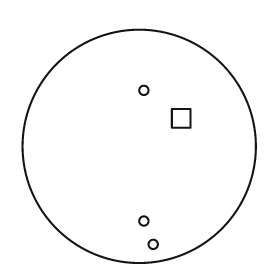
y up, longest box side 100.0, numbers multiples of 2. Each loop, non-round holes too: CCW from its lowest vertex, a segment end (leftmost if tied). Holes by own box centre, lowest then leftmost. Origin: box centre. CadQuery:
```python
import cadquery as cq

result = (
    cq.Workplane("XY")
    .moveTo(0.0, 0.0)
    .circle(50.0)
    .moveTo(6.0, -42.0)
    .circle(2.0)
    .moveTo(2.0, -32.0)
    .circle(2.0)
    .moveTo(14.0, 8.0)
    .lineTo(22.0, 8.0)
    .lineTo(22.0, 16.0)
    .lineTo(14.0, 16.0)
    .close()
    .moveTo(2.0, 24.0)
    .circle(2.0)
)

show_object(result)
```